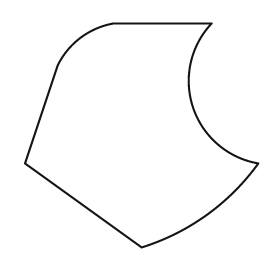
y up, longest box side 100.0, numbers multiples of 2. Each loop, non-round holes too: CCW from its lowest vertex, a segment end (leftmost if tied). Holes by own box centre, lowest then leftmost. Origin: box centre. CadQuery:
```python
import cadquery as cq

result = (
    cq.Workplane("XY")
    .moveTo(0.0, -48.0)
    .threePointArc((28.0, -34.0), (50.0, -12.0))
    .threePointArc((22.0, 12.0), (30.0, 48.0))
    .lineTo(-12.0, 48.0)
    .threePointArc((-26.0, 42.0), (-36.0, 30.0))
    .lineTo(-50.0, -12.0)
    .close()
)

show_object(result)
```